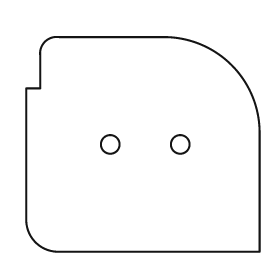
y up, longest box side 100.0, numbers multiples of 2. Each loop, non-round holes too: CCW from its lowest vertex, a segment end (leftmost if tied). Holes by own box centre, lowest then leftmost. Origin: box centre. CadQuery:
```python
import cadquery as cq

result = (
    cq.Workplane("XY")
    .moveTo(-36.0, -46.0)
    .lineTo(50.0, -46.0)
    .lineTo(50.0, 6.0)
    .threePointArc((38.0, 34.0), (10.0, 46.0))
    .lineTo(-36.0, 46.0)
    .threePointArc((-42.0, 44.0), (-44.0, 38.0))
    .lineTo(-44.0, 24.0)
    .lineTo(-50.0, 24.0)
    .lineTo(-50.0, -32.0)
    .threePointArc((-46.0, -42.0), (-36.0, -46.0))
    .close()
    .moveTo(-14.0, 0.0)
    .circle(4.0)
    .moveTo(16.0, 0.0)
    .circle(4.0)
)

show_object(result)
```